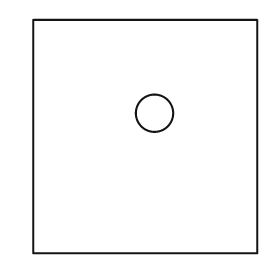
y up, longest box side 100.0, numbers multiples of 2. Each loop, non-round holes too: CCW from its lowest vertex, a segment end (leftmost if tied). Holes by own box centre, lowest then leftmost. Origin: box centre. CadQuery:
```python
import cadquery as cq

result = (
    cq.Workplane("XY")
    .moveTo(-48.0, -50.0)
    .lineTo(48.0, -50.0)
    .lineTo(48.0, 50.0)
    .lineTo(-48.0, 50.0)
    .close()
    .moveTo(4.0, 10.0)
    .circle(8.0)
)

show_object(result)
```